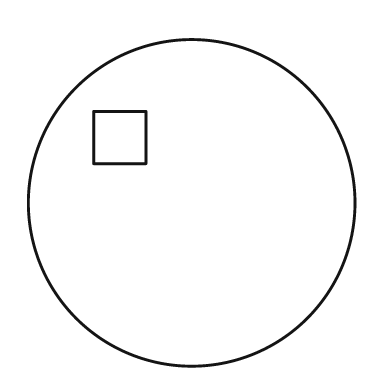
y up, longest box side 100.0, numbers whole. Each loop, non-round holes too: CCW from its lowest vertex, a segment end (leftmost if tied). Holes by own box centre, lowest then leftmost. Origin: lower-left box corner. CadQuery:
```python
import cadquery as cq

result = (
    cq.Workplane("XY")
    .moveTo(50.0, 50.0)
    .circle(50.0)
    .moveTo(20.0, 62.0)
    .lineTo(36.0, 62.0)
    .lineTo(36.0, 78.0)
    .lineTo(20.0, 78.0)
    .close()
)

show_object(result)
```